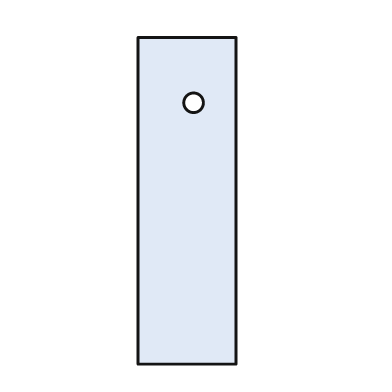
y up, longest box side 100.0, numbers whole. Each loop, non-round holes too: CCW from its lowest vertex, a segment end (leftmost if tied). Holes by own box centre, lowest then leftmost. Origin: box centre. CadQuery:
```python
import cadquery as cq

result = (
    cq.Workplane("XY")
    .moveTo(-15.0, -50.0)
    .lineTo(15.0, -50.0)
    .lineTo(15.0, 50.0)
    .lineTo(-15.0, 50.0)
    .close()
    .moveTo(2.0, 30.0)
    .circle(3.0)
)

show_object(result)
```